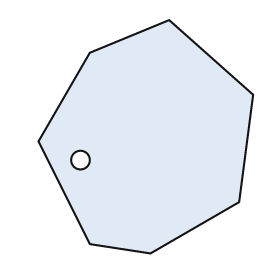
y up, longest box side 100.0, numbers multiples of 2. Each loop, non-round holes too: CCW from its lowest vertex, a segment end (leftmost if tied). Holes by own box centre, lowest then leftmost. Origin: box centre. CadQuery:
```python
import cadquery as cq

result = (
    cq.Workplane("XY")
    .moveTo(2.0, -50.0)
    .lineTo(40.0, -28.0)
    .lineTo(46.0, 18.0)
    .lineTo(10.0, 50.0)
    .lineTo(-24.0, 36.0)
    .lineTo(-46.0, -2.0)
    .lineTo(-24.0, -46.0)
    .close()
    .moveTo(-28.0, -10.0)
    .circle(4.0)
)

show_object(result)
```